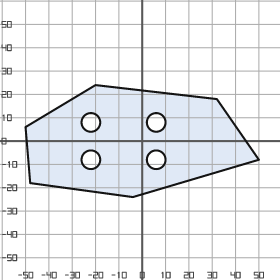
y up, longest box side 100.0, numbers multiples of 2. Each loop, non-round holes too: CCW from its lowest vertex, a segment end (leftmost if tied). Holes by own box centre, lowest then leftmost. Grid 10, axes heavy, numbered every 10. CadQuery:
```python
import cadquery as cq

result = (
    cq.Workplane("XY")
    .moveTo(-4.0, -24.0)
    .lineTo(50.0, -8.0)
    .lineTo(32.0, 18.0)
    .lineTo(-20.0, 24.0)
    .lineTo(-50.0, 6.0)
    .lineTo(-48.0, -18.0)
    .close()
    .moveTo(-22.0, -8.0)
    .circle(4.0)
    .moveTo(6.0, -8.0)
    .circle(4.0)
    .moveTo(-22.0, 8.0)
    .circle(4.0)
    .moveTo(6.0, 8.0)
    .circle(4.0)
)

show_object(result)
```